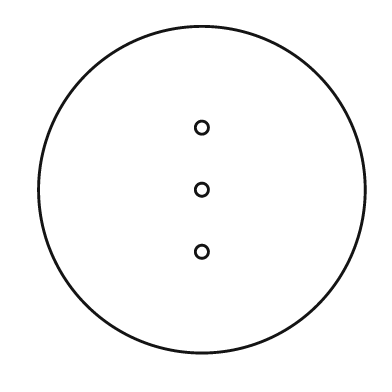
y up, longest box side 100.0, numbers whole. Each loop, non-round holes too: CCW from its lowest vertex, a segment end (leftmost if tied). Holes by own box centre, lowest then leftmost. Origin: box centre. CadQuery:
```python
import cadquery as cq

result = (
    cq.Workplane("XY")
    .moveTo(0.0, 0.0)
    .circle(50.0)
    .moveTo(0.0, -19.0)
    .circle(2.0)
    .moveTo(0.0, 0.0)
    .circle(2.0)
    .moveTo(0.0, 19.0)
    .circle(2.0)
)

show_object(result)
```